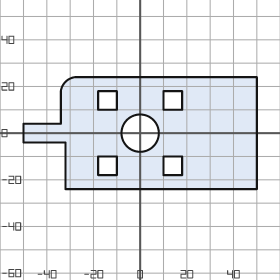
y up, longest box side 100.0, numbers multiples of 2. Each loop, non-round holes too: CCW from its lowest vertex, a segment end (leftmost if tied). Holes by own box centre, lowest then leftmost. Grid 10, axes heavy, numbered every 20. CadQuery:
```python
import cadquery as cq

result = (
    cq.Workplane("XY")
    .moveTo(-32.0, -24.0)
    .lineTo(50.0, -24.0)
    .lineTo(50.0, 24.0)
    .lineTo(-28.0, 24.0)
    .threePointArc((-32.0, 22.0), (-34.0, 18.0))
    .lineTo(-34.0, 4.0)
    .lineTo(-50.0, 4.0)
    .lineTo(-50.0, -4.0)
    .lineTo(-32.0, -4.0)
    .close()
    .moveTo(-18.0, -18.0)
    .lineTo(-10.0, -18.0)
    .lineTo(-10.0, -10.0)
    .lineTo(-18.0, -10.0)
    .close()
    .moveTo(10.0, -18.0)
    .lineTo(18.0, -18.0)
    .lineTo(18.0, -10.0)
    .lineTo(10.0, -10.0)
    .close()
    .moveTo(0.0, 0.0)
    .circle(8.0)
    .moveTo(-18.0, 10.0)
    .lineTo(-10.0, 10.0)
    .lineTo(-10.0, 18.0)
    .lineTo(-18.0, 18.0)
    .close()
    .moveTo(10.0, 10.0)
    .lineTo(18.0, 10.0)
    .lineTo(18.0, 18.0)
    .lineTo(10.0, 18.0)
    .close()
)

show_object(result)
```